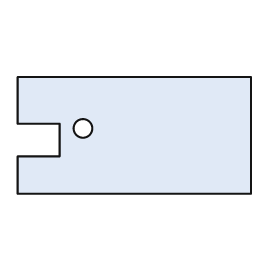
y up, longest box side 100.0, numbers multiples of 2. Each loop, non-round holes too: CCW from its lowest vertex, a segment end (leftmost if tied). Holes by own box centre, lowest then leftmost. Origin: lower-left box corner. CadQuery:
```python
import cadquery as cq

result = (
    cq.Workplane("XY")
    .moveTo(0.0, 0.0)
    .lineTo(100.0, 0.0)
    .lineTo(100.0, 50.0)
    .lineTo(0.0, 50.0)
    .lineTo(0.0, 30.0)
    .lineTo(18.0, 30.0)
    .lineTo(18.0, 16.0)
    .lineTo(0.0, 16.0)
    .close()
    .moveTo(28.0, 28.0)
    .circle(4.0)
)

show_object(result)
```